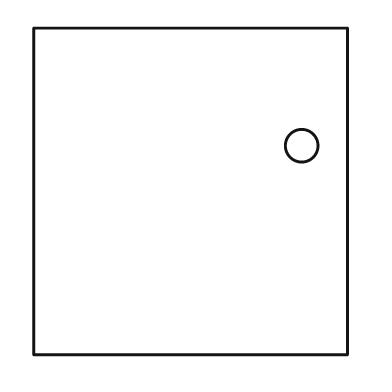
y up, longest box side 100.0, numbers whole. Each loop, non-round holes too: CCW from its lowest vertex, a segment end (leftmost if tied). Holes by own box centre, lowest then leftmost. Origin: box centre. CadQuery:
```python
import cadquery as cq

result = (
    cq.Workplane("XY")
    .moveTo(-48.0, -50.0)
    .lineTo(48.0, -50.0)
    .lineTo(48.0, 50.0)
    .lineTo(-48.0, 50.0)
    .close()
    .moveTo(34.0, 14.0)
    .circle(5.0)
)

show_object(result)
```